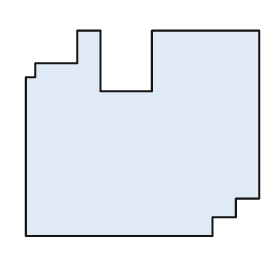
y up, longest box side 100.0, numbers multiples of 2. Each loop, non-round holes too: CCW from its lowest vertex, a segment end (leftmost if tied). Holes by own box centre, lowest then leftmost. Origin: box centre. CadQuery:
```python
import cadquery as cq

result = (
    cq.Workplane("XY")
    .moveTo(-50.0, -44.0)
    .lineTo(30.0, -44.0)
    .lineTo(30.0, -36.0)
    .lineTo(40.0, -36.0)
    .lineTo(40.0, -28.0)
    .lineTo(50.0, -28.0)
    .lineTo(50.0, 44.0)
    .lineTo(4.0, 44.0)
    .lineTo(4.0, 18.0)
    .lineTo(-18.0, 18.0)
    .lineTo(-18.0, 44.0)
    .lineTo(-28.0, 44.0)
    .lineTo(-28.0, 30.0)
    .lineTo(-46.0, 30.0)
    .lineTo(-46.0, 24.0)
    .lineTo(-50.0, 24.0)
    .close()
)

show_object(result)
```